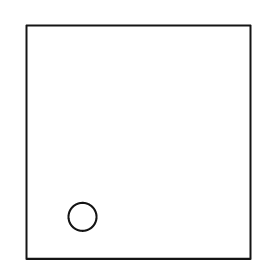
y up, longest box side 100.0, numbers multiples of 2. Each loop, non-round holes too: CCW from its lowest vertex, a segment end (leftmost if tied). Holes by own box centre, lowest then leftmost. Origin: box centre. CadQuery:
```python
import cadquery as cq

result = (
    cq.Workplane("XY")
    .moveTo(-48.0, -50.0)
    .lineTo(48.0, -50.0)
    .lineTo(48.0, 50.0)
    .lineTo(-48.0, 50.0)
    .close()
    .moveTo(-24.0, -32.0)
    .circle(6.0)
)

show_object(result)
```